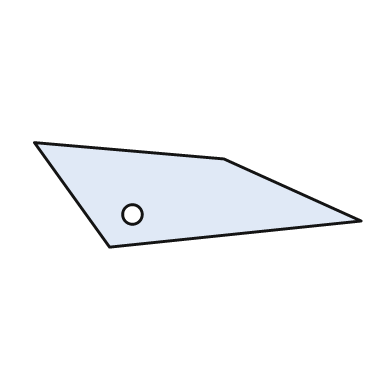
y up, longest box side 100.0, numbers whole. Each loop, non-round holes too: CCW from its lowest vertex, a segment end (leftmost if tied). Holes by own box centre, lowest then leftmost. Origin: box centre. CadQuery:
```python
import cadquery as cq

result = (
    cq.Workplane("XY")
    .moveTo(-27.0, -16.0)
    .lineTo(50.0, -8.0)
    .lineTo(8.0, 11.0)
    .lineTo(-50.0, 16.0)
    .close()
    .moveTo(-20.0, -6.0)
    .circle(3.0)
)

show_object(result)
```